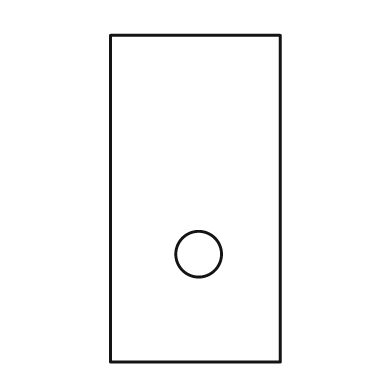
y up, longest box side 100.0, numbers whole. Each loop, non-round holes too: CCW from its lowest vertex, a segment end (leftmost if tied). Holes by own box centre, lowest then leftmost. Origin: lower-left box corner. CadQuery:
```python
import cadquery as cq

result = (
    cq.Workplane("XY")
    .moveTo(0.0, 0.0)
    .lineTo(52.0, 0.0)
    .lineTo(52.0, 100.0)
    .lineTo(0.0, 100.0)
    .close()
    .moveTo(27.0, 33.0)
    .circle(7.0)
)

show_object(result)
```